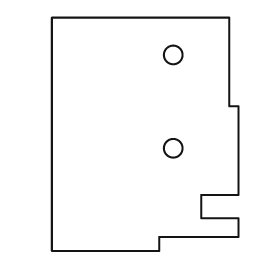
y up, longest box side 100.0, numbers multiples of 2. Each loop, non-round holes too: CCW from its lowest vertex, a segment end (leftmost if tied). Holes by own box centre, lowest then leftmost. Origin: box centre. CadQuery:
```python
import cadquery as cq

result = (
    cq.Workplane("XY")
    .moveTo(-40.0, -50.0)
    .lineTo(6.0, -50.0)
    .lineTo(6.0, -44.0)
    .lineTo(40.0, -44.0)
    .lineTo(40.0, -36.0)
    .lineTo(24.0, -36.0)
    .lineTo(24.0, -26.0)
    .lineTo(40.0, -26.0)
    .lineTo(40.0, 12.0)
    .lineTo(36.0, 12.0)
    .lineTo(36.0, 50.0)
    .lineTo(-40.0, 50.0)
    .close()
    .moveTo(12.0, -6.0)
    .circle(4.0)
    .moveTo(12.0, 34.0)
    .circle(4.0)
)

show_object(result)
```